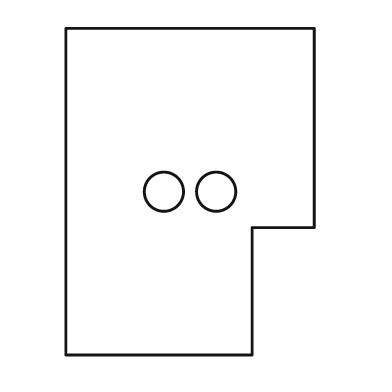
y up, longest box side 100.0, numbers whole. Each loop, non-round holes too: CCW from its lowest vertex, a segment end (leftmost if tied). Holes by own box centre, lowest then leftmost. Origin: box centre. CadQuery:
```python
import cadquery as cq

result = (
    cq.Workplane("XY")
    .moveTo(-38.0, -50.0)
    .lineTo(19.0, -50.0)
    .lineTo(19.0, -11.0)
    .lineTo(38.0, -11.0)
    .lineTo(38.0, 50.0)
    .lineTo(-38.0, 50.0)
    .close()
    .moveTo(-8.0, 0.0)
    .circle(6.0)
    .moveTo(8.0, 0.0)
    .circle(6.0)
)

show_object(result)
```